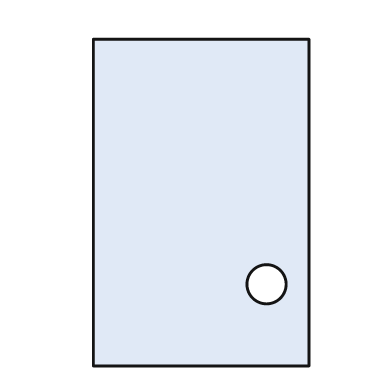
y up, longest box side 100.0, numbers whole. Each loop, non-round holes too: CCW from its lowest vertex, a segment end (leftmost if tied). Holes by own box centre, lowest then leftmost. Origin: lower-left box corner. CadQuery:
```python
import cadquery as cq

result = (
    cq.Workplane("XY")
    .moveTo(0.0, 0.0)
    .lineTo(66.0, 0.0)
    .lineTo(66.0, 100.0)
    .lineTo(0.0, 100.0)
    .close()
    .moveTo(53.0, 25.0)
    .circle(6.0)
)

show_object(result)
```